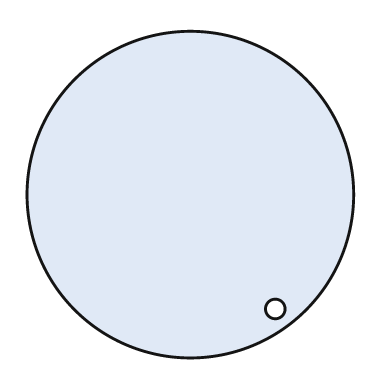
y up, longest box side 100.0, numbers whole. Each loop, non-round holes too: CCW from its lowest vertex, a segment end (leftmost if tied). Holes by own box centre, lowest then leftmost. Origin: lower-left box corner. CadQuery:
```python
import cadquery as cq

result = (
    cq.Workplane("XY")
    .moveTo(50.0, 50.0)
    .circle(50.0)
    .moveTo(76.0, 15.0)
    .circle(3.0)
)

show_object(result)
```